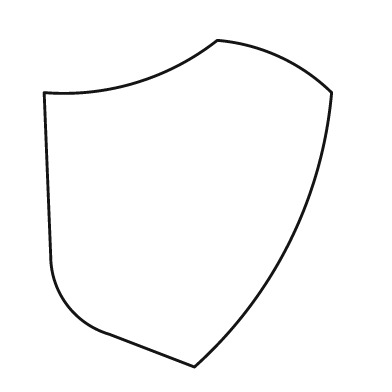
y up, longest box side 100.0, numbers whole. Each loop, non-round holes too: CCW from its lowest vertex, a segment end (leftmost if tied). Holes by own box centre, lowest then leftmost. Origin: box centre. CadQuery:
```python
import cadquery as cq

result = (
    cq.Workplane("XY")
    .moveTo(2.0, -50.0)
    .threePointArc((31.0, -12.0), (44.0, 34.0))
    .threePointArc((28.0, 45.0), (9.0, 50.0))
    .threePointArc((-16.0, 37.0), (-44.0, 34.0))
    .lineTo(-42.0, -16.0)
    .threePointArc((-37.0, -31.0), (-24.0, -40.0))
    .close()
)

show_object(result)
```